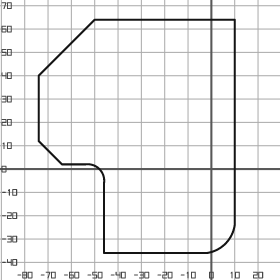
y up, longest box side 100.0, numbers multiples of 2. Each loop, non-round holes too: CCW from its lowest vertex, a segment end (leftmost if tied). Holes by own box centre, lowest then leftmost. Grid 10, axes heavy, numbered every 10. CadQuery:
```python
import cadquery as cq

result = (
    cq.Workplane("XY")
    .moveTo(-46.0, -36.0)
    .lineTo(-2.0, -36.0)
    .threePointArc((6.0, -32.0), (10.0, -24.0))
    .lineTo(10.0, 64.0)
    .lineTo(-50.0, 64.0)
    .lineTo(-74.0, 40.0)
    .lineTo(-74.0, 12.0)
    .lineTo(-64.0, 2.0)
    .lineTo(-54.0, 2.0)
    .threePointArc((-48.0, 0.0), (-46.0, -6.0))
    .close()
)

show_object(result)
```